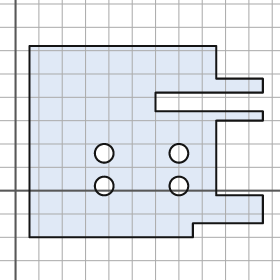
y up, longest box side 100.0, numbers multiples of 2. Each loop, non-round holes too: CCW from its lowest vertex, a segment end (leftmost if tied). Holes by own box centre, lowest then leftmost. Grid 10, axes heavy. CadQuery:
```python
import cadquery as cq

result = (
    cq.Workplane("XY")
    .moveTo(6.0, -20.0)
    .lineTo(76.0, -20.0)
    .lineTo(76.0, -14.0)
    .lineTo(106.0, -14.0)
    .lineTo(106.0, -2.0)
    .lineTo(86.0, -2.0)
    .lineTo(86.0, 30.0)
    .lineTo(106.0, 30.0)
    .lineTo(106.0, 34.0)
    .lineTo(60.0, 34.0)
    .lineTo(60.0, 42.0)
    .lineTo(106.0, 42.0)
    .lineTo(106.0, 48.0)
    .lineTo(86.0, 48.0)
    .lineTo(86.0, 62.0)
    .lineTo(6.0, 62.0)
    .close()
    .moveTo(38.0, 2.0)
    .circle(4.0)
    .moveTo(70.0, 2.0)
    .circle(4.0)
    .moveTo(38.0, 16.0)
    .circle(4.0)
    .moveTo(70.0, 16.0)
    .circle(4.0)
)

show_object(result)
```